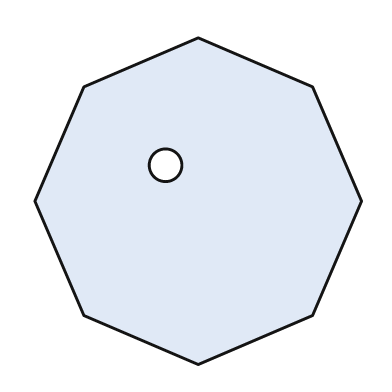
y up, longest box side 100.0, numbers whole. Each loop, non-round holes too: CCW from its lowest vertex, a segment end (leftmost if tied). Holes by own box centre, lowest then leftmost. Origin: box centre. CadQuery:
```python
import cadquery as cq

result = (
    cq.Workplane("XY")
    .moveTo(0.0, -50.0)
    .lineTo(35.0, -35.0)
    .lineTo(50.0, 0.0)
    .lineTo(35.0, 35.0)
    .lineTo(0.0, 50.0)
    .lineTo(-35.0, 35.0)
    .lineTo(-50.0, 0.0)
    .lineTo(-35.0, -35.0)
    .close()
    .moveTo(-10.0, 11.0)
    .circle(5.0)
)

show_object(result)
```